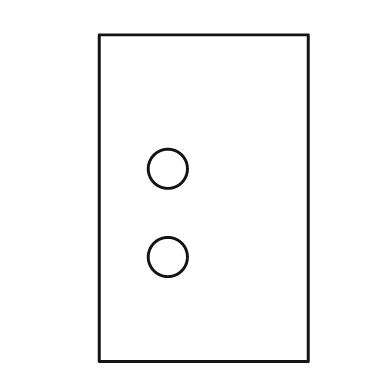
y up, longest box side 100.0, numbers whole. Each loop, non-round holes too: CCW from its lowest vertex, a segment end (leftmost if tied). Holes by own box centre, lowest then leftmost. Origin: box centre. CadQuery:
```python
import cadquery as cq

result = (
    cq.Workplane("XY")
    .moveTo(-32.0, -50.0)
    .lineTo(32.0, -50.0)
    .lineTo(32.0, 50.0)
    .lineTo(-32.0, 50.0)
    .close()
    .moveTo(-11.0, -18.0)
    .circle(6.0)
    .moveTo(-11.0, 9.0)
    .circle(6.0)
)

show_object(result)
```